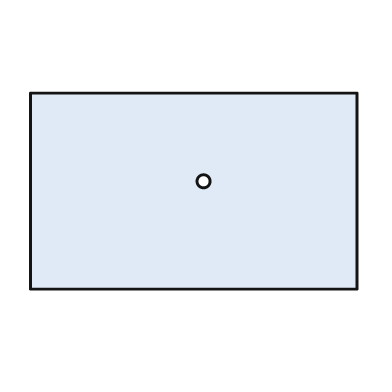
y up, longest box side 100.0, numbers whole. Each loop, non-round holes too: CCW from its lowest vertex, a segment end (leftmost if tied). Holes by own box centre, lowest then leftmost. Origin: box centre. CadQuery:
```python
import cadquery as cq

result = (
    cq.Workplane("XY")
    .moveTo(-50.0, -30.0)
    .lineTo(50.0, -30.0)
    .lineTo(50.0, 30.0)
    .lineTo(-50.0, 30.0)
    .close()
    .moveTo(3.0, 3.0)
    .circle(2.0)
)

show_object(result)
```